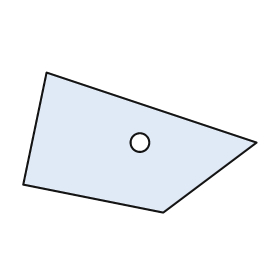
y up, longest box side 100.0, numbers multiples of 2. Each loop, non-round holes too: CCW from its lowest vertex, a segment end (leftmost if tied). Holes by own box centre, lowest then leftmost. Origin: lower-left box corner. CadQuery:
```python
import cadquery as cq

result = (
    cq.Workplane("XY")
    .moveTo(60.0, 0.0)
    .lineTo(100.0, 30.0)
    .lineTo(10.0, 60.0)
    .lineTo(0.0, 12.0)
    .close()
    .moveTo(50.0, 30.0)
    .circle(4.0)
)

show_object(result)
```